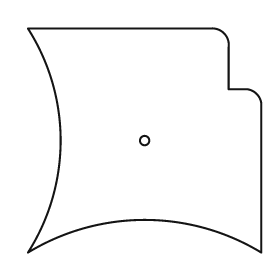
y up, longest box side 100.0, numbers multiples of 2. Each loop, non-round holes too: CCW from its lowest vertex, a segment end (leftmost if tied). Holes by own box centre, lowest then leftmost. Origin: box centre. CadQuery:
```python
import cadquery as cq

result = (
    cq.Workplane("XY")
    .moveTo(-50.0, -48.0)
    .threePointArc((0.0, -34.0), (50.0, -48.0))
    .lineTo(50.0, 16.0)
    .threePointArc((48.0, 20.0), (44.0, 22.0))
    .lineTo(36.0, 22.0)
    .lineTo(36.0, 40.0)
    .threePointArc((34.0, 46.0), (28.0, 48.0))
    .lineTo(-50.0, 48.0)
    .threePointArc((-36.0, 0.0), (-50.0, -48.0))
    .close()
    .moveTo(0.0, 0.0)
    .circle(2.0)
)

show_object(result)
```